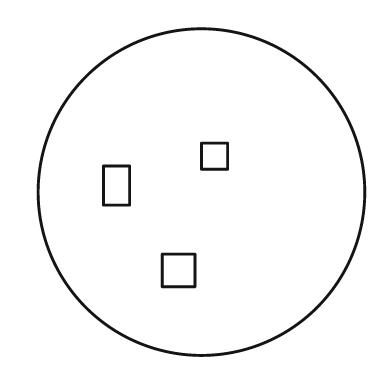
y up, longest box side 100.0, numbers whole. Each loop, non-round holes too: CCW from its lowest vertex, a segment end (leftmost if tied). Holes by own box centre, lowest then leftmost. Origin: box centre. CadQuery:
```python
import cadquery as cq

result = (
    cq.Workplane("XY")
    .moveTo(0.0, 0.0)
    .circle(50.0)
    .moveTo(-12.0, -29.0)
    .lineTo(-2.0, -29.0)
    .lineTo(-2.0, -19.0)
    .lineTo(-12.0, -19.0)
    .close()
    .moveTo(-30.0, -4.0)
    .lineTo(-22.0, -4.0)
    .lineTo(-22.0, 8.0)
    .lineTo(-30.0, 8.0)
    .close()
    .moveTo(0.0, 7.0)
    .lineTo(8.0, 7.0)
    .lineTo(8.0, 15.0)
    .lineTo(0.0, 15.0)
    .close()
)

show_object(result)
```